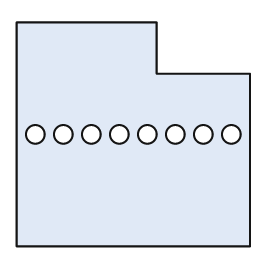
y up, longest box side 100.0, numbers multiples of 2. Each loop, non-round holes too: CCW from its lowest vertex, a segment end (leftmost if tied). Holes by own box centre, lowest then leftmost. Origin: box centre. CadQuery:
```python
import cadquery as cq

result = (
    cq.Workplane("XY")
    .moveTo(-50.0, -48.0)
    .lineTo(50.0, -48.0)
    .lineTo(50.0, 26.0)
    .lineTo(10.0, 26.0)
    .lineTo(10.0, 48.0)
    .lineTo(-50.0, 48.0)
    .close()
    .moveTo(-42.0, 0.0)
    .circle(4.0)
    .moveTo(-30.0, 0.0)
    .circle(4.0)
    .moveTo(-18.0, 0.0)
    .circle(4.0)
    .moveTo(-6.0, 0.0)
    .circle(4.0)
    .moveTo(6.0, 0.0)
    .circle(4.0)
    .moveTo(18.0, 0.0)
    .circle(4.0)
    .moveTo(30.0, 0.0)
    .circle(4.0)
    .moveTo(42.0, 0.0)
    .circle(4.0)
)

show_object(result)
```